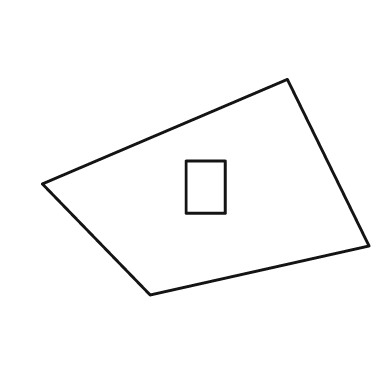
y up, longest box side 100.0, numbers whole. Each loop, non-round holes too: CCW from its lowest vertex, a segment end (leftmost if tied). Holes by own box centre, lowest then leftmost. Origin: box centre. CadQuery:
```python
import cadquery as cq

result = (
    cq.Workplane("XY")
    .moveTo(-17.0, -33.0)
    .lineTo(50.0, -18.0)
    .lineTo(25.0, 33.0)
    .lineTo(-50.0, 1.0)
    .close()
    .moveTo(-6.0, -8.0)
    .lineTo(6.0, -8.0)
    .lineTo(6.0, 8.0)
    .lineTo(-6.0, 8.0)
    .close()
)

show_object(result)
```